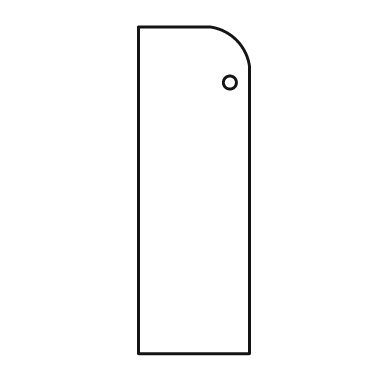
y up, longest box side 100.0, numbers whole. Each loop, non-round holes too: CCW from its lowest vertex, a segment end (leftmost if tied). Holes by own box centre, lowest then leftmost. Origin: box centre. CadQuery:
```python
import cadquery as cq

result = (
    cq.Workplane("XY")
    .moveTo(-17.0, -50.0)
    .lineTo(17.0, -50.0)
    .lineTo(17.0, 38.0)
    .threePointArc((13.0, 46.0), (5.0, 50.0))
    .lineTo(-17.0, 50.0)
    .close()
    .moveTo(11.0, 33.0)
    .circle(2.0)
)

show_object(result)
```